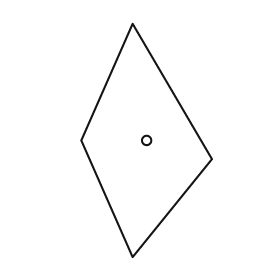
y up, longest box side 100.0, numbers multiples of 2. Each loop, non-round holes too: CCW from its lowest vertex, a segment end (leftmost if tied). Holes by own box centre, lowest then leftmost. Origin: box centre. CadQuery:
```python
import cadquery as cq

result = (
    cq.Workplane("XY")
    .moveTo(-6.0, -50.0)
    .lineTo(28.0, -8.0)
    .lineTo(-6.0, 50.0)
    .lineTo(-28.0, 0.0)
    .close()
    .moveTo(0.0, 0.0)
    .circle(2.0)
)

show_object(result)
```